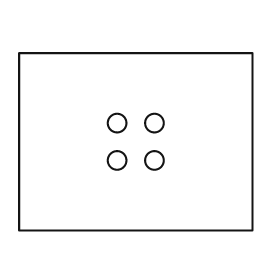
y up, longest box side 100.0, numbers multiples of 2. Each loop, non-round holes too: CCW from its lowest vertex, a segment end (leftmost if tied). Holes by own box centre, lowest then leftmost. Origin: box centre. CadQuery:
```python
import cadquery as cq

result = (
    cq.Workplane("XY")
    .moveTo(-50.0, -38.0)
    .lineTo(50.0, -38.0)
    .lineTo(50.0, 38.0)
    .lineTo(-50.0, 38.0)
    .close()
    .moveTo(-8.0, -8.0)
    .circle(4.0)
    .moveTo(8.0, -8.0)
    .circle(4.0)
    .moveTo(-8.0, 8.0)
    .circle(4.0)
    .moveTo(8.0, 8.0)
    .circle(4.0)
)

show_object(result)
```